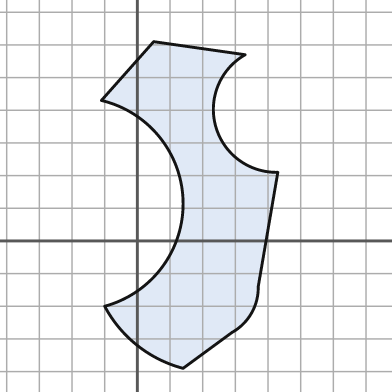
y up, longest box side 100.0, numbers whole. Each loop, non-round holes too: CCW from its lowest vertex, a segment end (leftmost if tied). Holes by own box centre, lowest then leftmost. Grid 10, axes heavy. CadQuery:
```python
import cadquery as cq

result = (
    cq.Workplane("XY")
    .moveTo(14.0, -39.0)
    .lineTo(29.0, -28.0)
    .threePointArc((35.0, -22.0), (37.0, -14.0))
    .lineTo(43.0, 21.0)
    .threePointArc((24.0, 35.0), (33.0, 57.0))
    .lineTo(5.0, 61.0)
    .lineTo(-11.0, 43.0)
    .threePointArc((14.0, 12.0), (-10.0, -20.0))
    .threePointArc((0.0, -32.0), (14.0, -39.0))
    .close()
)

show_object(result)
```